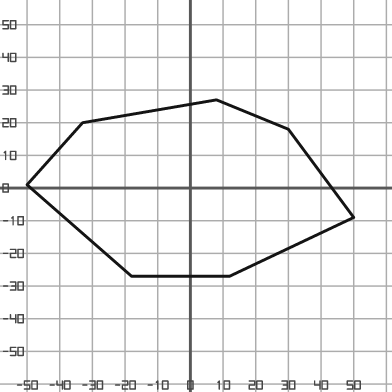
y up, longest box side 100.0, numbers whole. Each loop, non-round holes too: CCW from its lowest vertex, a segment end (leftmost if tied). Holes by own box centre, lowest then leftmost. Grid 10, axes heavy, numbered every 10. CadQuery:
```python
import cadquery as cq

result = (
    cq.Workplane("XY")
    .moveTo(-18.0, -27.0)
    .lineTo(12.0, -27.0)
    .lineTo(50.0, -9.0)
    .lineTo(30.0, 18.0)
    .lineTo(8.0, 27.0)
    .lineTo(-33.0, 20.0)
    .lineTo(-50.0, 1.0)
    .close()
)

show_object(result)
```